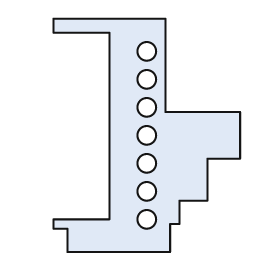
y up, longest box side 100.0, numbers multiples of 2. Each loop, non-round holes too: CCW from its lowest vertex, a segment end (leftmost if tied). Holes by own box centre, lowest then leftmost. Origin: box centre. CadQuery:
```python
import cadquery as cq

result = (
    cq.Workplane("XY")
    .moveTo(-34.0, -50.0)
    .lineTo(10.0, -50.0)
    .lineTo(10.0, -38.0)
    .lineTo(14.0, -38.0)
    .lineTo(14.0, -28.0)
    .lineTo(26.0, -28.0)
    .lineTo(26.0, -10.0)
    .lineTo(40.0, -10.0)
    .lineTo(40.0, 10.0)
    .lineTo(8.0, 10.0)
    .lineTo(8.0, 50.0)
    .lineTo(-40.0, 50.0)
    .lineTo(-40.0, 44.0)
    .lineTo(-16.0, 44.0)
    .lineTo(-16.0, -36.0)
    .lineTo(-40.0, -36.0)
    .lineTo(-40.0, -40.0)
    .lineTo(-34.0, -40.0)
    .close()
    .moveTo(0.0, -36.0)
    .circle(4.0)
    .moveTo(0.0, -24.0)
    .circle(4.0)
    .moveTo(0.0, -12.0)
    .circle(4.0)
    .moveTo(0.0, 0.0)
    .circle(4.0)
    .moveTo(0.0, 12.0)
    .circle(4.0)
    .moveTo(0.0, 24.0)
    .circle(4.0)
    .moveTo(0.0, 36.0)
    .circle(4.0)
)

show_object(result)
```